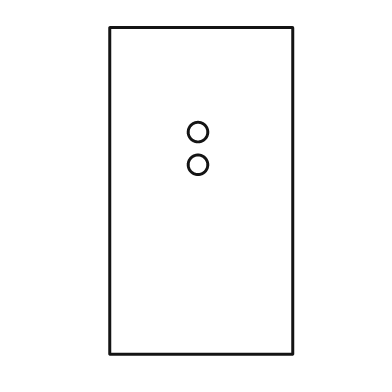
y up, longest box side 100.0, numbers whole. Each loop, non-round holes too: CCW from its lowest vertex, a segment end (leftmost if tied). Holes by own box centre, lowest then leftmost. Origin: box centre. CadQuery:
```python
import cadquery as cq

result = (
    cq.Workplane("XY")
    .moveTo(-28.0, -50.0)
    .lineTo(28.0, -50.0)
    .lineTo(28.0, 50.0)
    .lineTo(-28.0, 50.0)
    .close()
    .moveTo(-1.0, 8.0)
    .circle(3.0)
    .moveTo(-1.0, 18.0)
    .circle(3.0)
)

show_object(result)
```